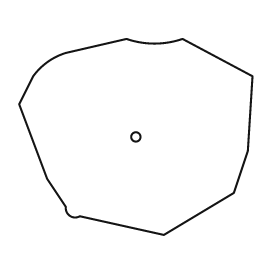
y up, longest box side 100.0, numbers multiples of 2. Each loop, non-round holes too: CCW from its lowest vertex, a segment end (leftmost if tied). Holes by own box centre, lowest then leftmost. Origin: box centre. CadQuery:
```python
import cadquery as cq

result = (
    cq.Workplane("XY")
    .moveTo(12.0, -42.0)
    .lineTo(42.0, -24.0)
    .lineTo(48.0, -6.0)
    .lineTo(50.0, 26.0)
    .lineTo(20.0, 42.0)
    .threePointArc((8.0, 40.0), (-4.0, 42.0))
    .lineTo(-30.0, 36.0)
    .threePointArc((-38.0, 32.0), (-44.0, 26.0))
    .lineTo(-50.0, 14.0)
    .lineTo(-38.0, -18.0)
    .lineTo(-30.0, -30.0)
    .threePointArc((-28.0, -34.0), (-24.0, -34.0))
    .close()
    .moveTo(0.0, 0.0)
    .circle(2.0)
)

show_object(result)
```